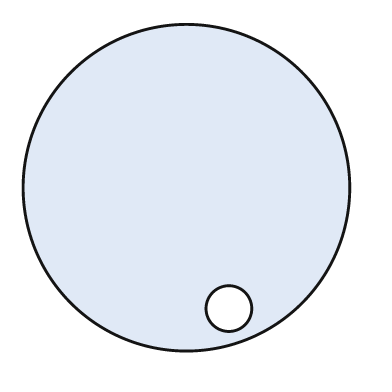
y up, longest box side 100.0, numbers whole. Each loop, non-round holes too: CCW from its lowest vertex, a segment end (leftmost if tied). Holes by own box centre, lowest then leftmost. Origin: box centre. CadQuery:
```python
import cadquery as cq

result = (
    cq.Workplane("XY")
    .moveTo(0.0, 0.0)
    .circle(50.0)
    .moveTo(13.0, -37.0)
    .circle(7.0)
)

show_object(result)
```